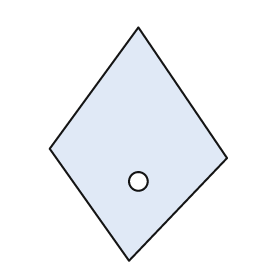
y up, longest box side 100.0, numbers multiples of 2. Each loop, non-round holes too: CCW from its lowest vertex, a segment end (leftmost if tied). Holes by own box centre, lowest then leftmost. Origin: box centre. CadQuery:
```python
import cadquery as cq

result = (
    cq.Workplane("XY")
    .moveTo(-4.0, -50.0)
    .lineTo(38.0, -6.0)
    .lineTo(0.0, 50.0)
    .lineTo(-38.0, -2.0)
    .close()
    .moveTo(0.0, -16.0)
    .circle(4.0)
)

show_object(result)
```